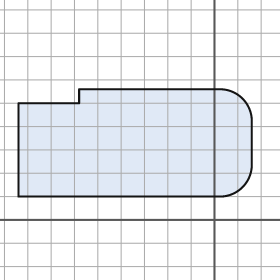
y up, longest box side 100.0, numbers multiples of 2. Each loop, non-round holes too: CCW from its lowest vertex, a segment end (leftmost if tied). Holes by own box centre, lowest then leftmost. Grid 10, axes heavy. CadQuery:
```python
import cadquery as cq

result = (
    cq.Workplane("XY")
    .moveTo(-84.0, 10.0)
    .lineTo(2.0, 10.0)
    .threePointArc((12.0, 14.0), (16.0, 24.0))
    .lineTo(16.0, 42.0)
    .threePointArc((12.0, 52.0), (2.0, 56.0))
    .lineTo(-58.0, 56.0)
    .lineTo(-58.0, 50.0)
    .lineTo(-84.0, 50.0)
    .close()
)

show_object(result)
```